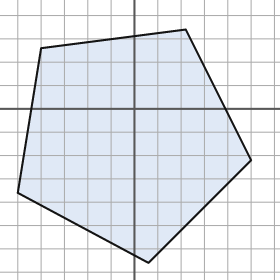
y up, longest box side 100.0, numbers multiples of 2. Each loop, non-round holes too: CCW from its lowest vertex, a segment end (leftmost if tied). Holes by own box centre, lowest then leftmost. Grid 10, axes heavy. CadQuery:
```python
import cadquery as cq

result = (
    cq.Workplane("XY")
    .moveTo(6.0, -66.0)
    .lineTo(50.0, -22.0)
    .lineTo(22.0, 34.0)
    .lineTo(-40.0, 26.0)
    .lineTo(-50.0, -36.0)
    .close()
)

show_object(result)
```